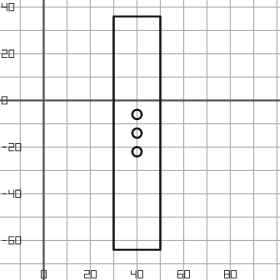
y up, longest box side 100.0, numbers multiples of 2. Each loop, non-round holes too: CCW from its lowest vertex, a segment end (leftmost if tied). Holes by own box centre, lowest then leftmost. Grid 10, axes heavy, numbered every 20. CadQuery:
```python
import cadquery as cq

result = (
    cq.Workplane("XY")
    .moveTo(30.0, -64.0)
    .lineTo(50.0, -64.0)
    .lineTo(50.0, 36.0)
    .lineTo(30.0, 36.0)
    .close()
    .moveTo(40.0, -22.0)
    .circle(2.0)
    .moveTo(40.0, -14.0)
    .circle(2.0)
    .moveTo(40.0, -6.0)
    .circle(2.0)
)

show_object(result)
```